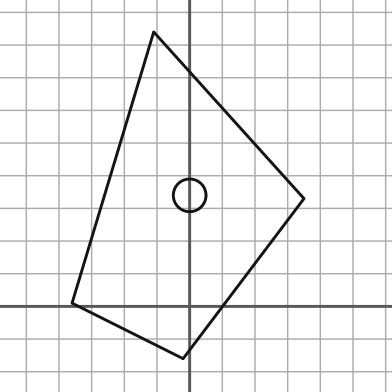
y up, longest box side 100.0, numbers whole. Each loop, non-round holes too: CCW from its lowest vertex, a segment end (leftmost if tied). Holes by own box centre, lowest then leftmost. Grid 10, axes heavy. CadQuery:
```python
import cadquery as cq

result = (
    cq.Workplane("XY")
    .moveTo(-2.0, -16.0)
    .lineTo(35.0, 33.0)
    .lineTo(-11.0, 84.0)
    .lineTo(-36.0, 1.0)
    .close()
    .moveTo(0.0, 34.0)
    .circle(5.0)
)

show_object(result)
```